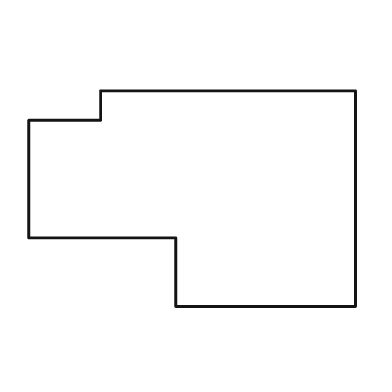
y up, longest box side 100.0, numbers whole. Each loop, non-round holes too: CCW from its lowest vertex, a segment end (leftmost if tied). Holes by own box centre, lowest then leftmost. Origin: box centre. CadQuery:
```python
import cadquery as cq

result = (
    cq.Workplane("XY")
    .moveTo(-5.0, -33.0)
    .lineTo(50.0, -33.0)
    .lineTo(50.0, 33.0)
    .lineTo(-28.0, 33.0)
    .lineTo(-28.0, 24.0)
    .lineTo(-50.0, 24.0)
    .lineTo(-50.0, -12.0)
    .lineTo(-5.0, -12.0)
    .close()
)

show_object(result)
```